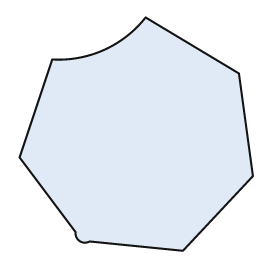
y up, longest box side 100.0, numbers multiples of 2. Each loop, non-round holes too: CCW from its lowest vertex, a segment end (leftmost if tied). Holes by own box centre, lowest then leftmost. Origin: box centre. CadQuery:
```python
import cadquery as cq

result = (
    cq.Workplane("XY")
    .moveTo(20.0, -50.0)
    .lineTo(50.0, -18.0)
    .lineTo(44.0, 26.0)
    .lineTo(4.0, 50.0)
    .threePointArc((-14.0, 36.0), (-36.0, 32.0))
    .lineTo(-50.0, -10.0)
    .lineTo(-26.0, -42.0)
    .threePointArc((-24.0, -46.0), (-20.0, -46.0))
    .close()
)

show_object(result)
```